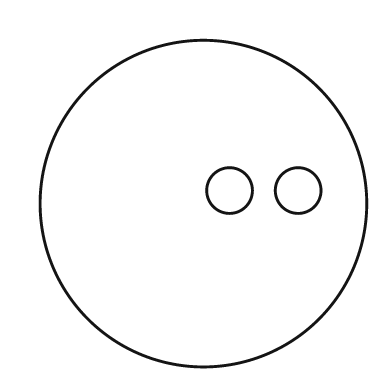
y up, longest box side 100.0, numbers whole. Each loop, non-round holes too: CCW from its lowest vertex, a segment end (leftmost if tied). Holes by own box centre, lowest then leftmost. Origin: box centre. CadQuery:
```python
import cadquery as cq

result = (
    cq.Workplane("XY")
    .moveTo(0.0, 0.0)
    .circle(50.0)
    .moveTo(8.0, 4.0)
    .circle(7.0)
    .moveTo(29.0, 4.0)
    .circle(7.0)
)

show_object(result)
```